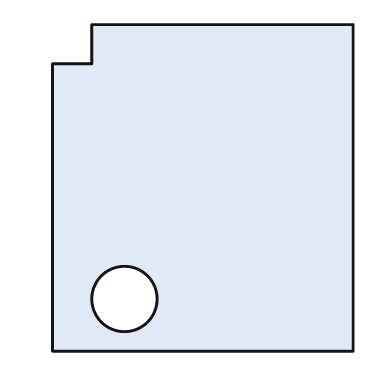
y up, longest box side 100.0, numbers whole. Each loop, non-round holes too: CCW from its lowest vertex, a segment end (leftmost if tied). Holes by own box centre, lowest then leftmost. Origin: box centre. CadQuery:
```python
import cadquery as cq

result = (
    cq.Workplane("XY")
    .moveTo(-46.0, -50.0)
    .lineTo(46.0, -50.0)
    .lineTo(46.0, 50.0)
    .lineTo(-34.0, 50.0)
    .lineTo(-34.0, 38.0)
    .lineTo(-46.0, 38.0)
    .close()
    .moveTo(-24.0, -34.0)
    .circle(10.0)
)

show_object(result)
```